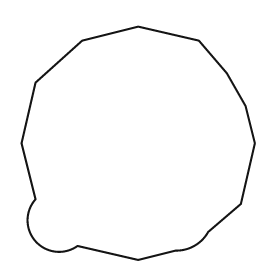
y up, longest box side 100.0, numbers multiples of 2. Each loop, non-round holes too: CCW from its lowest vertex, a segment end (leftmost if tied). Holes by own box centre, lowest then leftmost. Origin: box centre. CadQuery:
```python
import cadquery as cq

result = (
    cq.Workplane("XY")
    .moveTo(0.0, -50.0)
    .lineTo(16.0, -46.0)
    .threePointArc((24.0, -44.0), (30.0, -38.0))
    .lineTo(44.0, -26.0)
    .lineTo(50.0, 0.0)
    .lineTo(46.0, 16.0)
    .lineTo(38.0, 30.0)
    .lineTo(26.0, 44.0)
    .lineTo(0.0, 50.0)
    .lineTo(-24.0, 44.0)
    .lineTo(-44.0, 26.0)
    .lineTo(-50.0, 0.0)
    .lineTo(-44.0, -24.0)
    .threePointArc((-44.0, -42.0), (-26.0, -44.0))
    .close()
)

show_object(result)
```